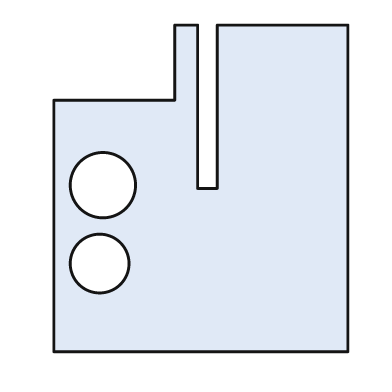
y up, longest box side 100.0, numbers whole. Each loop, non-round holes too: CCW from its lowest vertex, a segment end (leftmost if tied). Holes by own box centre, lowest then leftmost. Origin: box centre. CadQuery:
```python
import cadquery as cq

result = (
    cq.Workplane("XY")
    .moveTo(-45.0, -50.0)
    .lineTo(45.0, -50.0)
    .lineTo(45.0, 50.0)
    .lineTo(5.0, 50.0)
    .lineTo(5.0, 0.0)
    .lineTo(-1.0, 0.0)
    .lineTo(-1.0, 50.0)
    .lineTo(-8.0, 50.0)
    .lineTo(-8.0, 27.0)
    .lineTo(-45.0, 27.0)
    .close()
    .moveTo(-31.0, -23.0)
    .circle(9.0)
    .moveTo(-30.0, 1.0)
    .circle(10.0)
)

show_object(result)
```